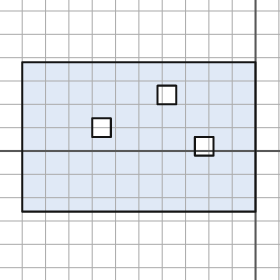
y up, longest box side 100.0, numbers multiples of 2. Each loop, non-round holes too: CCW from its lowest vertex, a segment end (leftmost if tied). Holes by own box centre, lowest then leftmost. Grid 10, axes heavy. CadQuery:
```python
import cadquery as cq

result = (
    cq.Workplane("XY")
    .moveTo(-100.0, -26.0)
    .lineTo(0.0, -26.0)
    .lineTo(0.0, 38.0)
    .lineTo(-100.0, 38.0)
    .close()
    .moveTo(-26.0, -2.0)
    .lineTo(-18.0, -2.0)
    .lineTo(-18.0, 6.0)
    .lineTo(-26.0, 6.0)
    .close()
    .moveTo(-70.0, 6.0)
    .lineTo(-62.0, 6.0)
    .lineTo(-62.0, 14.0)
    .lineTo(-70.0, 14.0)
    .close()
    .moveTo(-42.0, 20.0)
    .lineTo(-34.0, 20.0)
    .lineTo(-34.0, 28.0)
    .lineTo(-42.0, 28.0)
    .close()
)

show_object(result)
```